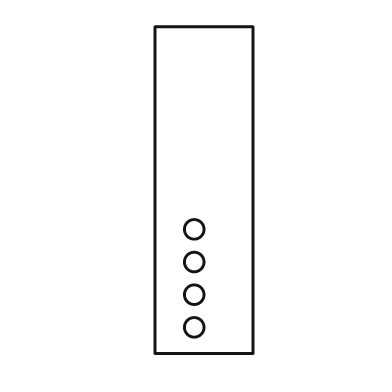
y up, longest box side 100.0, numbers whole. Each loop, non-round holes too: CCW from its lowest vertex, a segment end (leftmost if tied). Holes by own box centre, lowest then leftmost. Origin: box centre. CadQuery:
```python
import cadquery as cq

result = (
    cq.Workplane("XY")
    .moveTo(-15.0, -50.0)
    .lineTo(15.0, -50.0)
    .lineTo(15.0, 50.0)
    .lineTo(-15.0, 50.0)
    .close()
    .moveTo(-3.0, -42.0)
    .circle(3.0)
    .moveTo(-3.0, -32.0)
    .circle(3.0)
    .moveTo(-3.0, -22.0)
    .circle(3.0)
    .moveTo(-3.0, -12.0)
    .circle(3.0)
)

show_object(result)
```